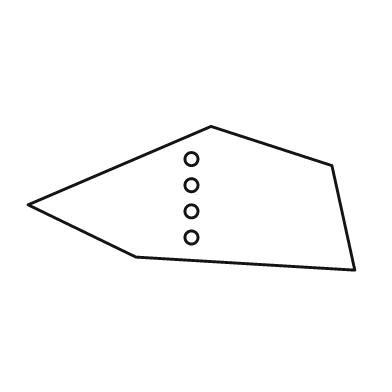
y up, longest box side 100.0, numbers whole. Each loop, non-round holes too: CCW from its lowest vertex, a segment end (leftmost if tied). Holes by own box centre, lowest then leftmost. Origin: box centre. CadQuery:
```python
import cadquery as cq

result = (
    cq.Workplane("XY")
    .moveTo(50.0, -22.0)
    .lineTo(43.0, 10.0)
    .lineTo(6.0, 22.0)
    .lineTo(-50.0, -2.0)
    .lineTo(-17.0, -18.0)
    .close()
    .moveTo(0.0, -12.0)
    .circle(2.0)
    .moveTo(0.0, -4.0)
    .circle(2.0)
    .moveTo(0.0, 4.0)
    .circle(2.0)
    .moveTo(0.0, 12.0)
    .circle(2.0)
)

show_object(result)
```